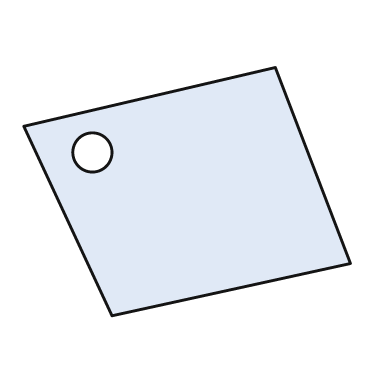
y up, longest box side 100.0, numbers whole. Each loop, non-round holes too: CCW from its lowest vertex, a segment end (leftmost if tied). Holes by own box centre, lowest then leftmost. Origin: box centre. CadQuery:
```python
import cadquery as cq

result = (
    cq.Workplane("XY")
    .moveTo(-23.0, -38.0)
    .lineTo(50.0, -22.0)
    .lineTo(27.0, 38.0)
    .lineTo(-50.0, 20.0)
    .close()
    .moveTo(-29.0, 12.0)
    .circle(6.0)
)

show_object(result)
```